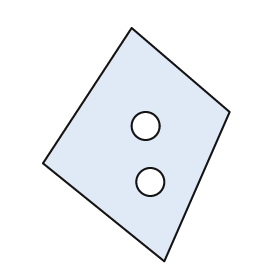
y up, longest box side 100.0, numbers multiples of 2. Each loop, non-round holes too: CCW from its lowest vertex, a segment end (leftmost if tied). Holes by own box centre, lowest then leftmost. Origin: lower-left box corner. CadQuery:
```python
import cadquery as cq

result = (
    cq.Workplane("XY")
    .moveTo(52.0, 0.0)
    .lineTo(80.0, 64.0)
    .lineTo(38.0, 100.0)
    .lineTo(0.0, 42.0)
    .close()
    .moveTo(46.0, 34.0)
    .circle(6.0)
    .moveTo(44.0, 58.0)
    .circle(6.0)
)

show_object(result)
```